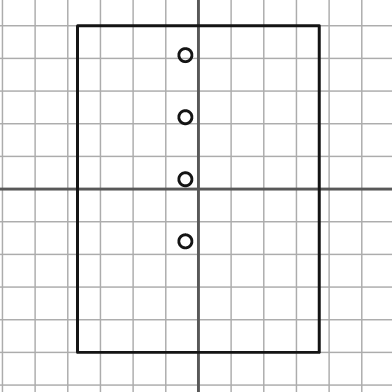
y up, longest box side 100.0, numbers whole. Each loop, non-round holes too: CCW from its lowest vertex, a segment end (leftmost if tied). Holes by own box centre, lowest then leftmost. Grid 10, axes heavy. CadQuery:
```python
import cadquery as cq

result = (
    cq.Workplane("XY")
    .moveTo(-37.0, -50.0)
    .lineTo(37.0, -50.0)
    .lineTo(37.0, 50.0)
    .lineTo(-37.0, 50.0)
    .close()
    .moveTo(-4.0, -16.0)
    .circle(2.0)
    .moveTo(-4.0, 3.0)
    .circle(2.0)
    .moveTo(-4.0, 22.0)
    .circle(2.0)
    .moveTo(-4.0, 41.0)
    .circle(2.0)
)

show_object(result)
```